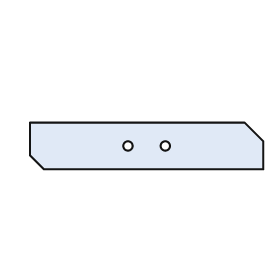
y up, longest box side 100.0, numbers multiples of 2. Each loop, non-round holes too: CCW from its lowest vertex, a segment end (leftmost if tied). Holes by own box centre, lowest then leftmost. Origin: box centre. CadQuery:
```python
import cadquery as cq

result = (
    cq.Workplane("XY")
    .moveTo(-44.0, -10.0)
    .lineTo(50.0, -10.0)
    .lineTo(50.0, 2.0)
    .lineTo(42.0, 10.0)
    .lineTo(-50.0, 10.0)
    .lineTo(-50.0, -4.0)
    .close()
    .moveTo(-8.0, 0.0)
    .circle(2.0)
    .moveTo(8.0, 0.0)
    .circle(2.0)
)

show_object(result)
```